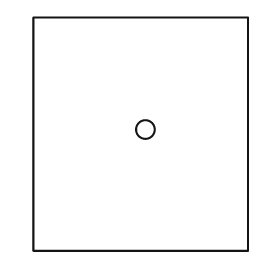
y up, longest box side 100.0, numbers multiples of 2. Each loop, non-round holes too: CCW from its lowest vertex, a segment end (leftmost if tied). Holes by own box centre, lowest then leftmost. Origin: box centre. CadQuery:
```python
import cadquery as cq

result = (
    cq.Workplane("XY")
    .moveTo(-46.0, -50.0)
    .lineTo(46.0, -50.0)
    .lineTo(46.0, 50.0)
    .lineTo(-46.0, 50.0)
    .close()
    .moveTo(2.0, 2.0)
    .circle(4.0)
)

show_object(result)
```